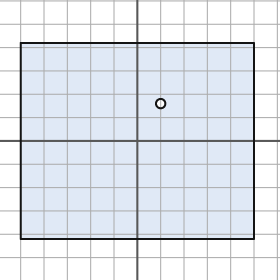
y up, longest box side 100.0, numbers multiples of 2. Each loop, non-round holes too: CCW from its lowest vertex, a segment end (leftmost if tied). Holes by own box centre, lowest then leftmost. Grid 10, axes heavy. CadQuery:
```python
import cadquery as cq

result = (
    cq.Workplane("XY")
    .moveTo(-50.0, -42.0)
    .lineTo(50.0, -42.0)
    .lineTo(50.0, 42.0)
    .lineTo(-50.0, 42.0)
    .close()
    .moveTo(10.0, 16.0)
    .circle(2.0)
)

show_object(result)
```